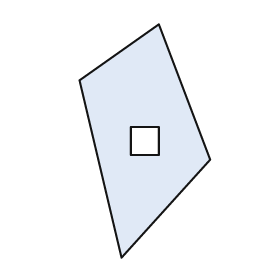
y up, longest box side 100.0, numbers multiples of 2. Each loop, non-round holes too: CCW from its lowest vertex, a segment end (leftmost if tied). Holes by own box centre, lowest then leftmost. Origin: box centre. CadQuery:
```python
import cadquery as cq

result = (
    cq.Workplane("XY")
    .moveTo(-10.0, -50.0)
    .lineTo(28.0, -8.0)
    .lineTo(6.0, 50.0)
    .lineTo(-28.0, 26.0)
    .close()
    .moveTo(-6.0, -6.0)
    .lineTo(6.0, -6.0)
    .lineTo(6.0, 6.0)
    .lineTo(-6.0, 6.0)
    .close()
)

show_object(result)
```